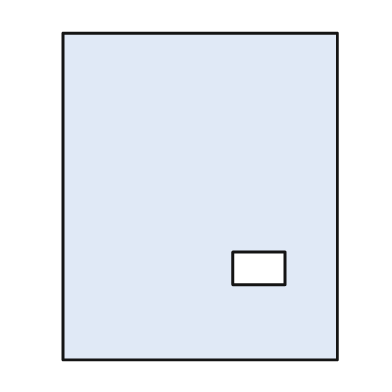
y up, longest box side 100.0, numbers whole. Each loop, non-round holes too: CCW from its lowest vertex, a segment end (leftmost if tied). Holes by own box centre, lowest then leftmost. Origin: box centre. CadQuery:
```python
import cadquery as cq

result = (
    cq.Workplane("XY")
    .moveTo(-42.0, -50.0)
    .lineTo(42.0, -50.0)
    .lineTo(42.0, 50.0)
    .lineTo(-42.0, 50.0)
    .close()
    .moveTo(10.0, -27.0)
    .lineTo(26.0, -27.0)
    .lineTo(26.0, -17.0)
    .lineTo(10.0, -17.0)
    .close()
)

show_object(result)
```